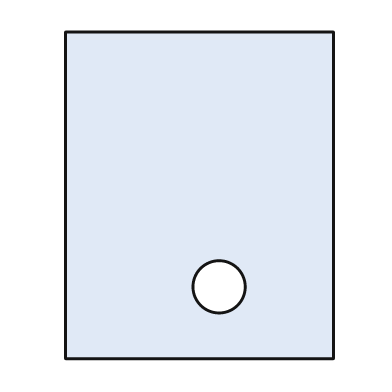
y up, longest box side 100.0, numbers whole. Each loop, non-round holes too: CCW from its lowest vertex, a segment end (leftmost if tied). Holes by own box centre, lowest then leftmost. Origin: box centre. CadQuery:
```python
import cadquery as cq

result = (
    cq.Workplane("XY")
    .moveTo(-41.0, -50.0)
    .lineTo(41.0, -50.0)
    .lineTo(41.0, 50.0)
    .lineTo(-41.0, 50.0)
    .close()
    .moveTo(6.0, -28.0)
    .circle(8.0)
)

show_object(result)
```